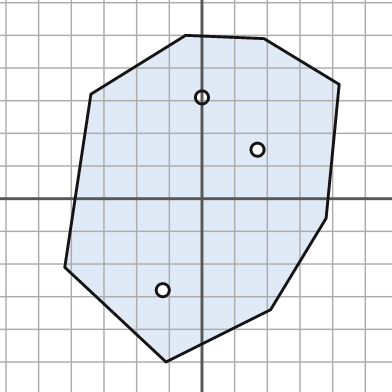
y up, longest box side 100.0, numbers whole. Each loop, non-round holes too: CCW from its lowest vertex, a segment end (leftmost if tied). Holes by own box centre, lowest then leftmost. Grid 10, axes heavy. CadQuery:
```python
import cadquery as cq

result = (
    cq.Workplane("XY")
    .moveTo(-11.0, -50.0)
    .lineTo(21.0, -34.0)
    .lineTo(38.0, -6.0)
    .lineTo(42.0, 35.0)
    .lineTo(19.0, 49.0)
    .lineTo(-5.0, 50.0)
    .lineTo(-34.0, 32.0)
    .lineTo(-42.0, -21.0)
    .close()
    .moveTo(-12.0, -28.0)
    .circle(2.0)
    .moveTo(17.0, 15.0)
    .circle(2.0)
    .moveTo(0.0, 31.0)
    .circle(2.0)
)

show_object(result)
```